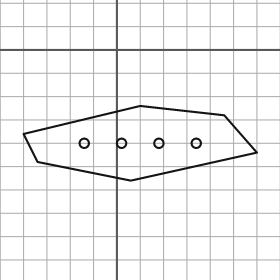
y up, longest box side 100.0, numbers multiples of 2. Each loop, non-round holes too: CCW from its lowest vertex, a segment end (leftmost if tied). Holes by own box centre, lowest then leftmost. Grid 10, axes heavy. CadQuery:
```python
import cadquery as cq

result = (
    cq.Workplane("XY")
    .moveTo(6.0, -56.0)
    .lineTo(60.0, -44.0)
    .lineTo(46.0, -28.0)
    .lineTo(10.0, -24.0)
    .lineTo(-40.0, -36.0)
    .lineTo(-34.0, -48.0)
    .close()
    .moveTo(-14.0, -40.0)
    .circle(2.0)
    .moveTo(2.0, -40.0)
    .circle(2.0)
    .moveTo(18.0, -40.0)
    .circle(2.0)
    .moveTo(34.0, -40.0)
    .circle(2.0)
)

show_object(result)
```